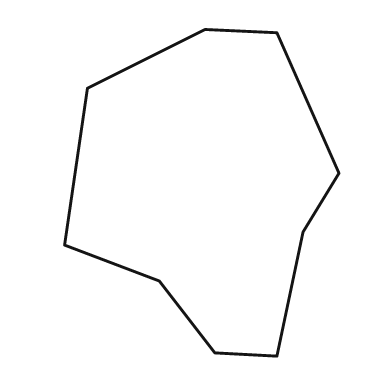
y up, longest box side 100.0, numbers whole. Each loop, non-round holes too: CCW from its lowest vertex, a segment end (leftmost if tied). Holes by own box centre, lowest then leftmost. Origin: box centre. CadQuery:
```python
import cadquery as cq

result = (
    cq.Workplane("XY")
    .moveTo(23.0, -50.0)
    .lineTo(31.0, -12.0)
    .lineTo(42.0, 6.0)
    .lineTo(23.0, 49.0)
    .lineTo(1.0, 50.0)
    .lineTo(-35.0, 32.0)
    .lineTo(-42.0, -16.0)
    .lineTo(-13.0, -27.0)
    .lineTo(4.0, -49.0)
    .close()
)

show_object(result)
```